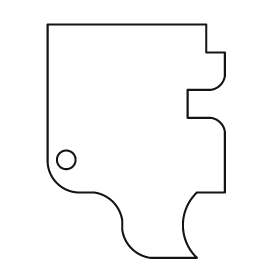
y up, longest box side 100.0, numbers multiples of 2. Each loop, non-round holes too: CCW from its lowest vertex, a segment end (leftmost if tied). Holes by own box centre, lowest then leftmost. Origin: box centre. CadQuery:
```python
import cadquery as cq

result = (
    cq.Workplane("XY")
    .moveTo(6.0, -50.0)
    .lineTo(26.0, -50.0)
    .threePointArc((20.0, -36.0), (26.0, -22.0))
    .lineTo(38.0, -22.0)
    .lineTo(38.0, 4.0)
    .threePointArc((36.0, 8.0), (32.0, 10.0))
    .lineTo(22.0, 10.0)
    .lineTo(22.0, 22.0)
    .lineTo(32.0, 22.0)
    .threePointArc((36.0, 24.0), (38.0, 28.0))
    .lineTo(38.0, 38.0)
    .lineTo(30.0, 38.0)
    .lineTo(30.0, 50.0)
    .lineTo(-38.0, 50.0)
    .lineTo(-38.0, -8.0)
    .threePointArc((-34.0, -18.0), (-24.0, -22.0))
    .lineTo(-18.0, -22.0)
    .threePointArc((-10.0, -26.0), (-6.0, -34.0))
    .lineTo(-6.0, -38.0)
    .threePointArc((-2.0, -46.0), (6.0, -50.0))
    .close()
    .moveTo(-30.0, -8.0)
    .circle(4.0)
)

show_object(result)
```